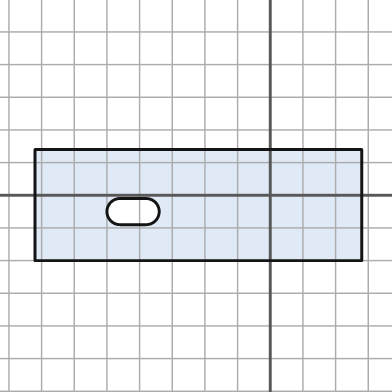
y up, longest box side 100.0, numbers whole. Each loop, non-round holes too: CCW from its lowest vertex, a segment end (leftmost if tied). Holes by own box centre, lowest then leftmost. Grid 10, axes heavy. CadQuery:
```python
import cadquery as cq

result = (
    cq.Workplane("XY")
    .moveTo(-72.0, -20.0)
    .lineTo(28.0, -20.0)
    .lineTo(28.0, 14.0)
    .lineTo(-72.0, 14.0)
    .close()
    .moveTo(-46.0, -9.0)
    .lineTo(-38.0, -9.0)
    .threePointArc((-34.0, -5.0), (-38.0, -1.0))
    .lineTo(-46.0, -1.0)
    .threePointArc((-50.0, -5.0), (-46.0, -9.0))
    .close()
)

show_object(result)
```